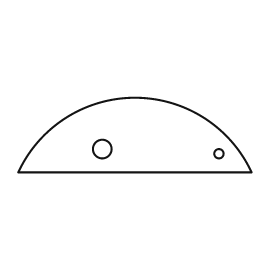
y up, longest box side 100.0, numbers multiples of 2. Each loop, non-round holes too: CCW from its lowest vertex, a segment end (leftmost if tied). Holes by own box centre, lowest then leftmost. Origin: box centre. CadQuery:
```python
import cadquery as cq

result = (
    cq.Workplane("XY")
    .moveTo(-50.0, -16.0)
    .lineTo(50.0, -16.0)
    .threePointArc((0.0, 16.0), (-50.0, -16.0))
    .close()
    .moveTo(36.0, -8.0)
    .circle(2.0)
    .moveTo(-14.0, -6.0)
    .circle(4.0)
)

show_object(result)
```